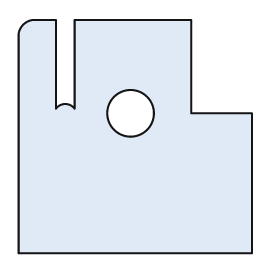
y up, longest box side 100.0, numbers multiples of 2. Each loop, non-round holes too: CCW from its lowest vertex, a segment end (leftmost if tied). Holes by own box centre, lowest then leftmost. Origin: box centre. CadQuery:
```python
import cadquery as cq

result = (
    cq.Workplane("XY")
    .moveTo(-50.0, -50.0)
    .lineTo(50.0, -50.0)
    .lineTo(50.0, 10.0)
    .lineTo(24.0, 10.0)
    .lineTo(24.0, 50.0)
    .lineTo(-26.0, 50.0)
    .lineTo(-26.0, 12.0)
    .threePointArc((-30.0, 14.0), (-34.0, 12.0))
    .lineTo(-34.0, 50.0)
    .lineTo(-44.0, 50.0)
    .threePointArc((-48.0, 48.0), (-50.0, 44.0))
    .close()
    .moveTo(-2.0, 10.0)
    .circle(10.0)
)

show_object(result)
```